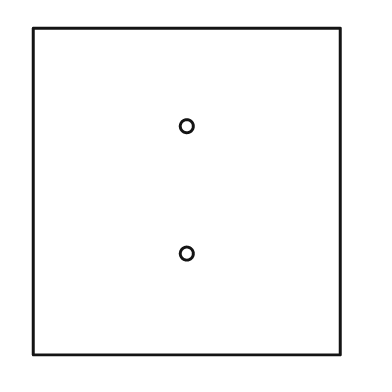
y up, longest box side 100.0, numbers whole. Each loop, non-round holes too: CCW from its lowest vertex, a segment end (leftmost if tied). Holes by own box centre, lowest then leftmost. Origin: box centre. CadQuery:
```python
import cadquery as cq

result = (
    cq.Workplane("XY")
    .moveTo(-47.0, -50.0)
    .lineTo(47.0, -50.0)
    .lineTo(47.0, 50.0)
    .lineTo(-47.0, 50.0)
    .close()
    .moveTo(0.0, -19.0)
    .circle(2.0)
    .moveTo(0.0, 20.0)
    .circle(2.0)
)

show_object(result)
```